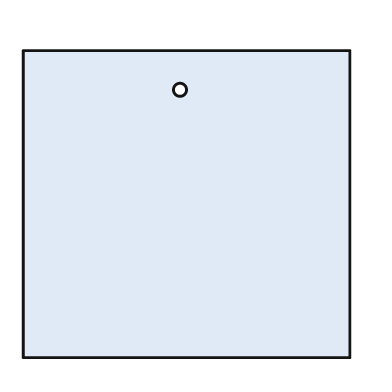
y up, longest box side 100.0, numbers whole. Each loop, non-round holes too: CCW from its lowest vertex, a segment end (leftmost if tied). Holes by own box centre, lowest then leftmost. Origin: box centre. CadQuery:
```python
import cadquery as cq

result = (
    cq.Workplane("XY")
    .moveTo(-50.0, -47.0)
    .lineTo(50.0, -47.0)
    .lineTo(50.0, 47.0)
    .lineTo(-50.0, 47.0)
    .close()
    .moveTo(-2.0, 35.0)
    .circle(2.0)
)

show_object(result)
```